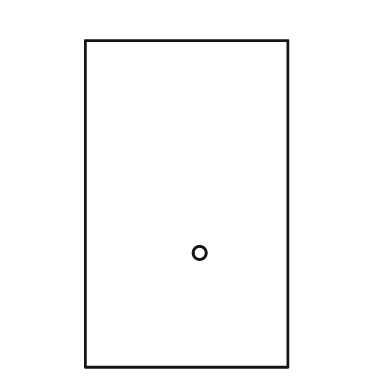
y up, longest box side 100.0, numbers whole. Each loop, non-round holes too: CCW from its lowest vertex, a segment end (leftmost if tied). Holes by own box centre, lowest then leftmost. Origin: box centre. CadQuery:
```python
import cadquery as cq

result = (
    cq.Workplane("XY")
    .moveTo(-31.0, -50.0)
    .lineTo(31.0, -50.0)
    .lineTo(31.0, 50.0)
    .lineTo(-31.0, 50.0)
    .close()
    .moveTo(4.0, -15.0)
    .circle(2.0)
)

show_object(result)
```